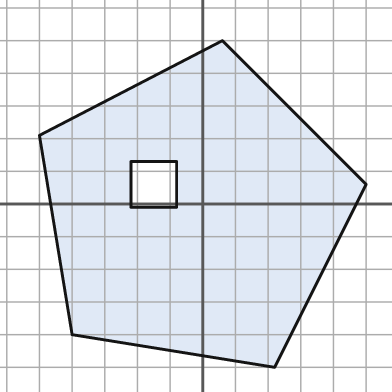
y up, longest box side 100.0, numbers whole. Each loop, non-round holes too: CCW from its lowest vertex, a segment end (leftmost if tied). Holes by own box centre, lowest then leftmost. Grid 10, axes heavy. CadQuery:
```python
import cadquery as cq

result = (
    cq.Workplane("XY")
    .moveTo(22.0, -50.0)
    .lineTo(50.0, 6.0)
    .lineTo(6.0, 50.0)
    .lineTo(-50.0, 21.0)
    .lineTo(-40.0, -40.0)
    .close()
    .moveTo(-22.0, -1.0)
    .lineTo(-8.0, -1.0)
    .lineTo(-8.0, 13.0)
    .lineTo(-22.0, 13.0)
    .close()
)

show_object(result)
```